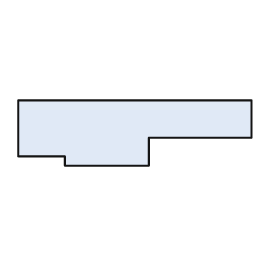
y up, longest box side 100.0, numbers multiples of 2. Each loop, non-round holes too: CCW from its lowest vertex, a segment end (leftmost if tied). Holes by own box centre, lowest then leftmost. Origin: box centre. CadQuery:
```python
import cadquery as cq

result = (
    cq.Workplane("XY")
    .moveTo(-30.0, -14.0)
    .lineTo(6.0, -14.0)
    .lineTo(6.0, -2.0)
    .lineTo(50.0, -2.0)
    .lineTo(50.0, 14.0)
    .lineTo(-50.0, 14.0)
    .lineTo(-50.0, -10.0)
    .lineTo(-30.0, -10.0)
    .close()
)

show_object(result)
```